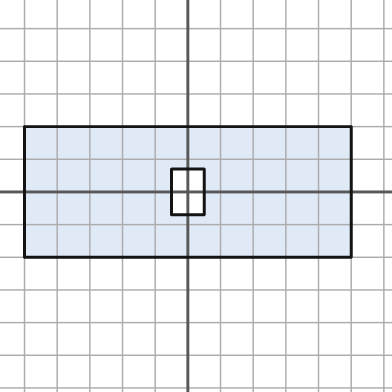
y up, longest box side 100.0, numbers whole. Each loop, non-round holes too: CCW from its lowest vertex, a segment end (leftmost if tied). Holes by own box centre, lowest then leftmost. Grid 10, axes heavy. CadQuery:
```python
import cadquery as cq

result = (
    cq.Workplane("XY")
    .moveTo(-50.0, -20.0)
    .lineTo(50.0, -20.0)
    .lineTo(50.0, 20.0)
    .lineTo(-50.0, 20.0)
    .close()
    .moveTo(-5.0, -7.0)
    .lineTo(5.0, -7.0)
    .lineTo(5.0, 7.0)
    .lineTo(-5.0, 7.0)
    .close()
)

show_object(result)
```